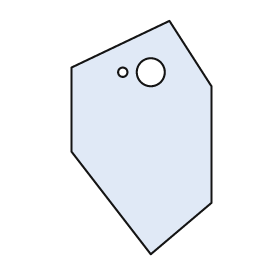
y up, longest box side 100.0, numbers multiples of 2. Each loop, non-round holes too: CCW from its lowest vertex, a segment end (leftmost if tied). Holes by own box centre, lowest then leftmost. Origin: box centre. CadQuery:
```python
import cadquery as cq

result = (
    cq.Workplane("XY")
    .moveTo(4.0, -50.0)
    .lineTo(30.0, -28.0)
    .lineTo(30.0, 22.0)
    .lineTo(12.0, 50.0)
    .lineTo(-30.0, 30.0)
    .lineTo(-30.0, -6.0)
    .close()
    .moveTo(-8.0, 28.0)
    .circle(2.0)
    .moveTo(4.0, 28.0)
    .circle(6.0)
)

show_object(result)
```